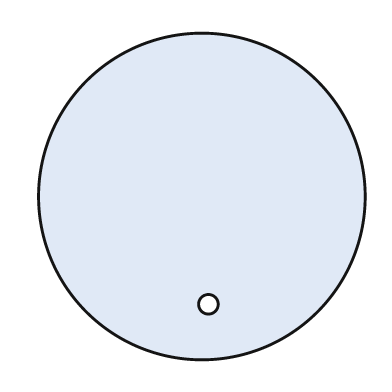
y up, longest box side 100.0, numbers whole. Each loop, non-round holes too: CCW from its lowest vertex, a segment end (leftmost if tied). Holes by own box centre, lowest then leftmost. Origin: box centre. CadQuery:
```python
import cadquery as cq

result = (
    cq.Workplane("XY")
    .moveTo(0.0, 0.0)
    .circle(50.0)
    .moveTo(2.0, -33.0)
    .circle(3.0)
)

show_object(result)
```